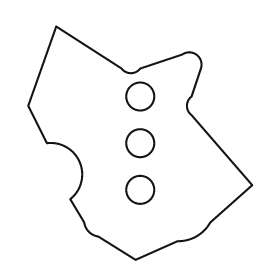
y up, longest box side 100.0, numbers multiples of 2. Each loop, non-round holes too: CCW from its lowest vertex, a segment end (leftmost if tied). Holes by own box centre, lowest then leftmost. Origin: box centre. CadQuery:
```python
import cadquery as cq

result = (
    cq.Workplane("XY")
    .moveTo(-2.0, -50.0)
    .lineTo(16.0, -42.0)
    .threePointArc((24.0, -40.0), (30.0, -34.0))
    .lineTo(48.0, -18.0)
    .lineTo(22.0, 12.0)
    .threePointArc((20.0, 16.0), (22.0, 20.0))
    .lineTo(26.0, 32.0)
    .threePointArc((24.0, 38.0), (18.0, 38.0))
    .lineTo(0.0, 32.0)
    .threePointArc((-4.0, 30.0), (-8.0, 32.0))
    .lineTo(-36.0, 50.0)
    .lineTo(-48.0, 16.0)
    .lineTo(-40.0, 0.0)
    .threePointArc((-26.0, -8.0), (-30.0, -24.0))
    .lineTo(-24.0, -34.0)
    .threePointArc((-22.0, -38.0), (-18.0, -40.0))
    .close()
    .moveTo(0.0, -20.0)
    .circle(6.0)
    .moveTo(0.0, 0.0)
    .circle(6.0)
    .moveTo(0.0, 20.0)
    .circle(6.0)
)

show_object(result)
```